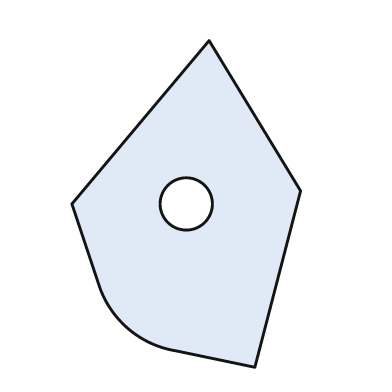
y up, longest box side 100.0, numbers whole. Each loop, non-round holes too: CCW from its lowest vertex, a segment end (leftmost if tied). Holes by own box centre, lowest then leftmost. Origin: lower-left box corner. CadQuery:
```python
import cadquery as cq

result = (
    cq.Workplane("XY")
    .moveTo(56.0, 0.0)
    .lineTo(70.0, 54.0)
    .lineTo(42.0, 100.0)
    .lineTo(0.0, 50.0)
    .lineTo(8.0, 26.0)
    .threePointArc((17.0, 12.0), (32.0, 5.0))
    .close()
    .moveTo(35.0, 50.0)
    .circle(8.0)
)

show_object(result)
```